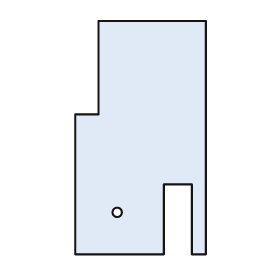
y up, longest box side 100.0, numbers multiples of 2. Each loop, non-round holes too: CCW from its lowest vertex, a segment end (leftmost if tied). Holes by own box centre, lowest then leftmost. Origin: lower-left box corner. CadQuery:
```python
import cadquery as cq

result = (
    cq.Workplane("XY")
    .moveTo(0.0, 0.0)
    .lineTo(38.0, 0.0)
    .lineTo(38.0, 30.0)
    .lineTo(50.0, 30.0)
    .lineTo(50.0, 0.0)
    .lineTo(56.0, 0.0)
    .lineTo(56.0, 100.0)
    .lineTo(10.0, 100.0)
    .lineTo(10.0, 60.0)
    .lineTo(0.0, 60.0)
    .close()
    .moveTo(18.0, 18.0)
    .circle(2.0)
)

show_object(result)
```